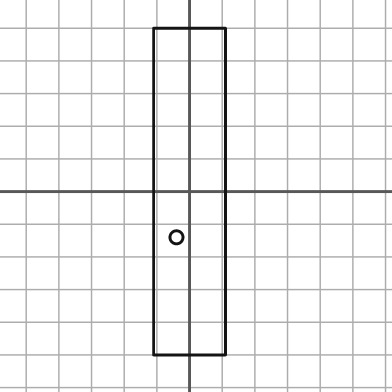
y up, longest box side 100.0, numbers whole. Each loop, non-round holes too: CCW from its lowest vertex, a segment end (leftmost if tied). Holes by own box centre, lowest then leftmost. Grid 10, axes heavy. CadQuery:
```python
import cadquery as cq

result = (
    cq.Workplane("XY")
    .moveTo(-11.0, -50.0)
    .lineTo(11.0, -50.0)
    .lineTo(11.0, 50.0)
    .lineTo(-11.0, 50.0)
    .close()
    .moveTo(-4.0, -14.0)
    .circle(2.0)
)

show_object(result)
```